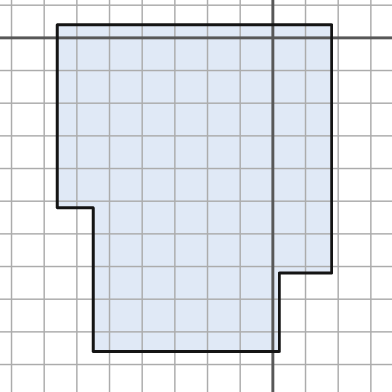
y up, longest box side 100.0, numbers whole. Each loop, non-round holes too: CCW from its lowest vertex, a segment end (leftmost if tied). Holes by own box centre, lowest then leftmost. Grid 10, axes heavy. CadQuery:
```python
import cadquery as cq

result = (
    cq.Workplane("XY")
    .moveTo(-55.0, -96.0)
    .lineTo(2.0, -96.0)
    .lineTo(2.0, -72.0)
    .lineTo(18.0, -72.0)
    .lineTo(18.0, 4.0)
    .lineTo(-66.0, 4.0)
    .lineTo(-66.0, -52.0)
    .lineTo(-55.0, -52.0)
    .close()
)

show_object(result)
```